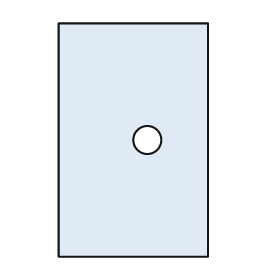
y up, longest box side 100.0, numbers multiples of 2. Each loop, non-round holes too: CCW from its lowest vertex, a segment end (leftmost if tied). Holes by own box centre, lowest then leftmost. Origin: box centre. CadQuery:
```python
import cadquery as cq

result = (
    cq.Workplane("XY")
    .moveTo(-32.0, -50.0)
    .lineTo(32.0, -50.0)
    .lineTo(32.0, 50.0)
    .lineTo(-32.0, 50.0)
    .close()
    .moveTo(6.0, 0.0)
    .circle(6.0)
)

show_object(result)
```